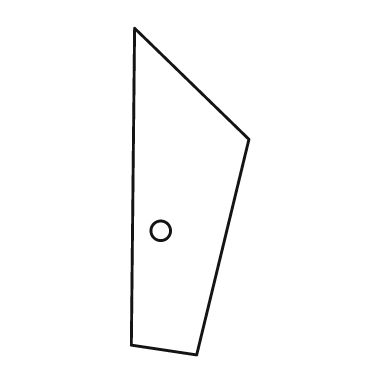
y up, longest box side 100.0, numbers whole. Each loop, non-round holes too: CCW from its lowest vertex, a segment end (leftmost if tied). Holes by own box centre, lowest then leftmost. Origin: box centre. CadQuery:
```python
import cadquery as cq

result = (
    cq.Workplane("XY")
    .moveTo(2.0, -50.0)
    .lineTo(18.0, 16.0)
    .lineTo(-17.0, 50.0)
    .lineTo(-18.0, -47.0)
    .close()
    .moveTo(-9.0, -12.0)
    .circle(3.0)
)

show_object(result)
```